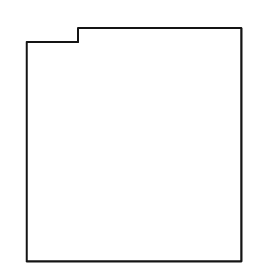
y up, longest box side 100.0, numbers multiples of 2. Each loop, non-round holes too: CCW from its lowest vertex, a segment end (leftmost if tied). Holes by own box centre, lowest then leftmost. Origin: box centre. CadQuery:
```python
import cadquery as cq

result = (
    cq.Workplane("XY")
    .moveTo(-46.0, -50.0)
    .lineTo(46.0, -50.0)
    .lineTo(46.0, 50.0)
    .lineTo(-24.0, 50.0)
    .lineTo(-24.0, 44.0)
    .lineTo(-46.0, 44.0)
    .close()
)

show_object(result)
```